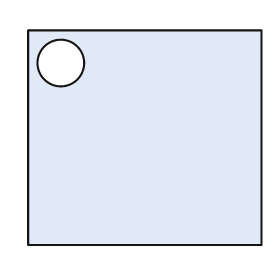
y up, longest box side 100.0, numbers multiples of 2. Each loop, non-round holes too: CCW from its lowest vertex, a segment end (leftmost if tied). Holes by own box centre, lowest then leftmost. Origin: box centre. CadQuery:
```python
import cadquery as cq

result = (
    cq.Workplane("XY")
    .moveTo(-50.0, -46.0)
    .lineTo(50.0, -46.0)
    .lineTo(50.0, 46.0)
    .lineTo(-50.0, 46.0)
    .close()
    .moveTo(-36.0, 32.0)
    .circle(10.0)
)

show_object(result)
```